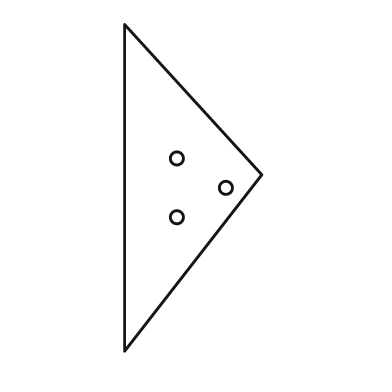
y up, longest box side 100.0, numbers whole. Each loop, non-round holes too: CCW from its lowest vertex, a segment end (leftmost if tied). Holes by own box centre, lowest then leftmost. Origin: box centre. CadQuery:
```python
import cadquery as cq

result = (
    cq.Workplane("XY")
    .moveTo(-21.0, -50.0)
    .lineTo(21.0, 4.0)
    .lineTo(-21.0, 50.0)
    .close()
    .moveTo(-5.0, -9.0)
    .circle(2.0)
    .moveTo(10.0, 0.0)
    .circle(2.0)
    .moveTo(-5.0, 9.0)
    .circle(2.0)
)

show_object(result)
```